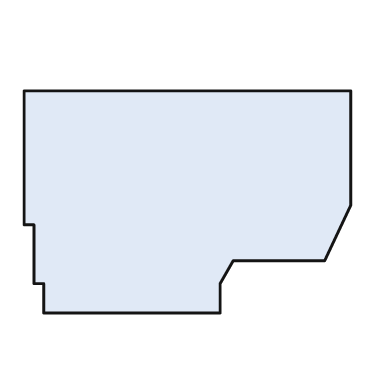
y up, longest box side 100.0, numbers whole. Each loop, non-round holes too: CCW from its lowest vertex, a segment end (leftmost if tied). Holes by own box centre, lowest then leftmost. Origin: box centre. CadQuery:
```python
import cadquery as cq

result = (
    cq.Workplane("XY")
    .moveTo(-44.0, -34.0)
    .lineTo(10.0, -34.0)
    .lineTo(10.0, -25.0)
    .lineTo(14.0, -18.0)
    .lineTo(42.0, -18.0)
    .lineTo(50.0, -1.0)
    .lineTo(50.0, 34.0)
    .lineTo(-50.0, 34.0)
    .lineTo(-50.0, -7.0)
    .lineTo(-47.0, -7.0)
    .lineTo(-47.0, -25.0)
    .lineTo(-44.0, -25.0)
    .close()
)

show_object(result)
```